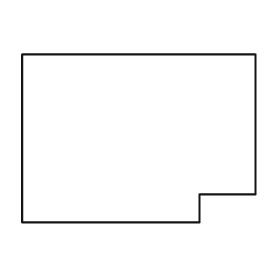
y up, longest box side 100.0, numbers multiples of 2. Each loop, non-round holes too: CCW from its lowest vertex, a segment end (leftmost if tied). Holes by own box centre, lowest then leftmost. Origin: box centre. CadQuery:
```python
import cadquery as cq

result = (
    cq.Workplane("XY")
    .moveTo(-50.0, -36.0)
    .lineTo(26.0, -36.0)
    .lineTo(26.0, -24.0)
    .lineTo(50.0, -24.0)
    .lineTo(50.0, 36.0)
    .lineTo(-50.0, 36.0)
    .close()
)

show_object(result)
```